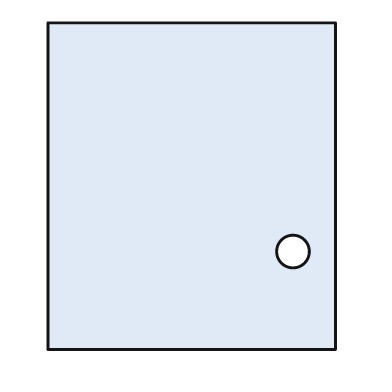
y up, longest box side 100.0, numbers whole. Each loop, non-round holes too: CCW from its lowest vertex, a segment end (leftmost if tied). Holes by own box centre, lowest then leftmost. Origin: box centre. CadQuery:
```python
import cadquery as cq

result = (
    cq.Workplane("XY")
    .moveTo(-44.0, -50.0)
    .lineTo(44.0, -50.0)
    .lineTo(44.0, 50.0)
    .lineTo(-44.0, 50.0)
    .close()
    .moveTo(31.0, -20.0)
    .circle(5.0)
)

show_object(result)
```